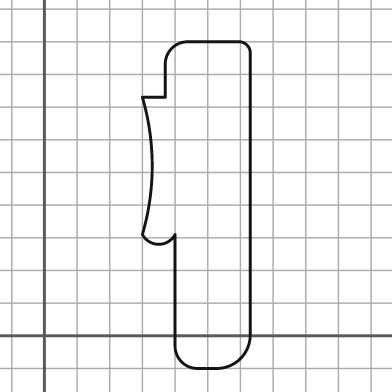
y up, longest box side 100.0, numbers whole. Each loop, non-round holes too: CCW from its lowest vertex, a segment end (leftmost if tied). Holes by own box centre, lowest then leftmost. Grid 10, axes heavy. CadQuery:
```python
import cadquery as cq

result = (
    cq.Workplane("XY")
    .moveTo(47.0, -10.0)
    .lineTo(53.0, -10.0)
    .threePointArc((60.0, -7.0), (63.0, 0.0))
    .lineTo(63.0, 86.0)
    .threePointArc((62.0, 89.0), (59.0, 90.0))
    .lineTo(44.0, 90.0)
    .threePointArc((39.0, 88.0), (37.0, 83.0))
    .lineTo(37.0, 73.0)
    .lineTo(30.0, 73.0)
    .threePointArc((33.0, 52.0), (30.0, 31.0))
    .threePointArc((35.0, 28.0), (40.0, 31.0))
    .lineTo(40.0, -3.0)
    .threePointArc((42.0, -8.0), (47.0, -10.0))
    .close()
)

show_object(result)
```